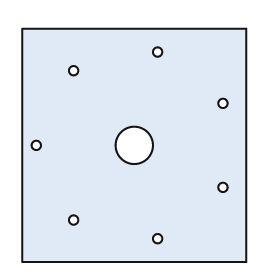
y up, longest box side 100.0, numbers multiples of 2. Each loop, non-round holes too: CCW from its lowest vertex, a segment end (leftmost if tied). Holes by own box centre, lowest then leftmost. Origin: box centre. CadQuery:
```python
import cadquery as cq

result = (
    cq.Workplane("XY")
    .moveTo(-48.0, -50.0)
    .lineTo(48.0, -50.0)
    .lineTo(48.0, 50.0)
    .lineTo(-48.0, 50.0)
    .close()
    .moveTo(10.0, -40.0)
    .circle(2.0)
    .moveTo(-26.0, -32.0)
    .circle(2.0)
    .moveTo(38.0, -18.0)
    .circle(2.0)
    .moveTo(-42.0, 0.0)
    .circle(2.0)
    .moveTo(0.0, 0.0)
    .circle(8.0)
    .moveTo(38.0, 18.0)
    .circle(2.0)
    .moveTo(-26.0, 32.0)
    .circle(2.0)
    .moveTo(10.0, 40.0)
    .circle(2.0)
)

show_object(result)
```